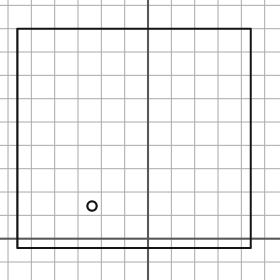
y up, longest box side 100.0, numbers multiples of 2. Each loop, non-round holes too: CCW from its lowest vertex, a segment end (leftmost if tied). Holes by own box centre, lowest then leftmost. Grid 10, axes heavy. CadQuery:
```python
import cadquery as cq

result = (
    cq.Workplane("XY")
    .moveTo(-56.0, -4.0)
    .lineTo(44.0, -4.0)
    .lineTo(44.0, 90.0)
    .lineTo(-56.0, 90.0)
    .close()
    .moveTo(-24.0, 14.0)
    .circle(2.0)
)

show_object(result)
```